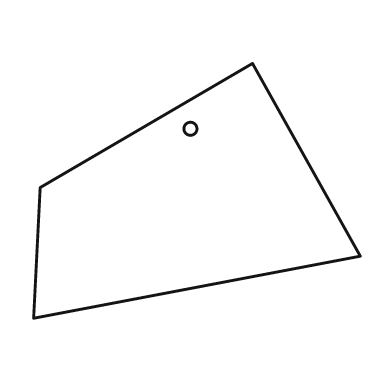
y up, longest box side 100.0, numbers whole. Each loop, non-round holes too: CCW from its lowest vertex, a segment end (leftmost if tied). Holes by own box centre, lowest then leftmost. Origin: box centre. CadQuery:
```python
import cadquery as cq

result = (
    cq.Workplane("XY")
    .moveTo(-50.0, -39.0)
    .lineTo(50.0, -20.0)
    .lineTo(17.0, 39.0)
    .lineTo(-48.0, 1.0)
    .close()
    .moveTo(-2.0, 19.0)
    .circle(2.0)
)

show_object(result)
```